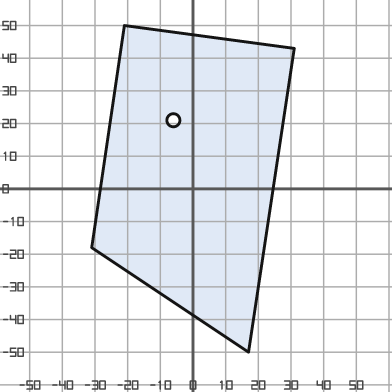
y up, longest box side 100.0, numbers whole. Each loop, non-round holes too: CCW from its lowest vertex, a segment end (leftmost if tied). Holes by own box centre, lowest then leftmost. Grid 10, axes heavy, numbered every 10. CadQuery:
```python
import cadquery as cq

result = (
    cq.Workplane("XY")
    .moveTo(17.0, -50.0)
    .lineTo(31.0, 43.0)
    .lineTo(-21.0, 50.0)
    .lineTo(-31.0, -18.0)
    .close()
    .moveTo(-6.0, 21.0)
    .circle(2.0)
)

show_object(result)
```